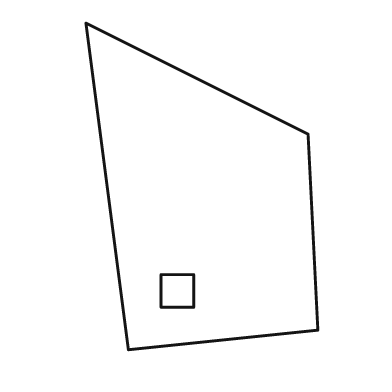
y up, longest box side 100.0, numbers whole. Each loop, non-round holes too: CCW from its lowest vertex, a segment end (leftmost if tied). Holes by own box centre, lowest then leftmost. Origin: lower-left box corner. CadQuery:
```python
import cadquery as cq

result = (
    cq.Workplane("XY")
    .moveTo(13.0, 0.0)
    .lineTo(71.0, 6.0)
    .lineTo(68.0, 66.0)
    .lineTo(0.0, 100.0)
    .close()
    .moveTo(23.0, 13.0)
    .lineTo(33.0, 13.0)
    .lineTo(33.0, 23.0)
    .lineTo(23.0, 23.0)
    .close()
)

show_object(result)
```